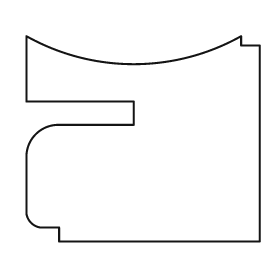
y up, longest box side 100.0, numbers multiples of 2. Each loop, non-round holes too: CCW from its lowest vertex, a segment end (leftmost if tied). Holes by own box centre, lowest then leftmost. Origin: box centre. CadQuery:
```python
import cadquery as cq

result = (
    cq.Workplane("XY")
    .moveTo(-36.0, -44.0)
    .lineTo(50.0, -44.0)
    .lineTo(50.0, 40.0)
    .lineTo(42.0, 40.0)
    .lineTo(42.0, 44.0)
    .threePointArc((-4.0, 32.0), (-50.0, 44.0))
    .lineTo(-50.0, 16.0)
    .lineTo(-4.0, 16.0)
    .lineTo(-4.0, 6.0)
    .lineTo(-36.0, 6.0)
    .threePointArc((-46.0, 2.0), (-50.0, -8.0))
    .lineTo(-50.0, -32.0)
    .threePointArc((-48.0, -36.0), (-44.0, -38.0))
    .lineTo(-36.0, -38.0)
    .close()
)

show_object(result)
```